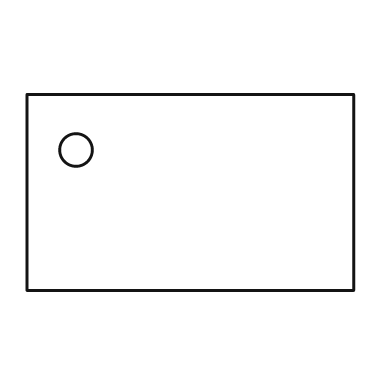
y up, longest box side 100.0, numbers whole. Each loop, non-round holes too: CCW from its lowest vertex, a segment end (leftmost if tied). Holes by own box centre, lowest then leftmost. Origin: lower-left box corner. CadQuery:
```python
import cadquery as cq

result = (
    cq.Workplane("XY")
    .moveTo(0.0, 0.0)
    .lineTo(100.0, 0.0)
    .lineTo(100.0, 60.0)
    .lineTo(0.0, 60.0)
    .close()
    .moveTo(15.0, 43.0)
    .circle(5.0)
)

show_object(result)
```